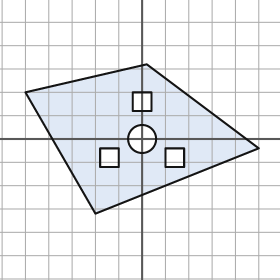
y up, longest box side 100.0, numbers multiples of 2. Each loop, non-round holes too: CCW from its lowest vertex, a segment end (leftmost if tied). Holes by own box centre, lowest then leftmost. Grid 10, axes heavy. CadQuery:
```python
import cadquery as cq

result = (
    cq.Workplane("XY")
    .moveTo(-20.0, -32.0)
    .lineTo(50.0, -4.0)
    .lineTo(2.0, 32.0)
    .lineTo(-50.0, 20.0)
    .close()
    .moveTo(-18.0, -12.0)
    .lineTo(-10.0, -12.0)
    .lineTo(-10.0, -4.0)
    .lineTo(-18.0, -4.0)
    .close()
    .moveTo(10.0, -12.0)
    .lineTo(18.0, -12.0)
    .lineTo(18.0, -4.0)
    .lineTo(10.0, -4.0)
    .close()
    .moveTo(0.0, 0.0)
    .circle(6.0)
    .moveTo(-4.0, 12.0)
    .lineTo(4.0, 12.0)
    .lineTo(4.0, 20.0)
    .lineTo(-4.0, 20.0)
    .close()
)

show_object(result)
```